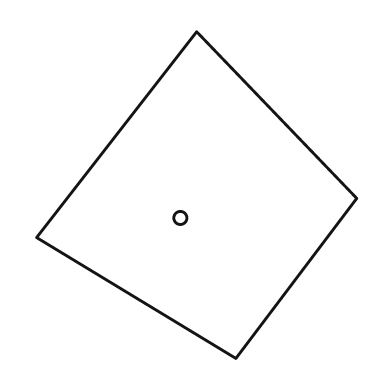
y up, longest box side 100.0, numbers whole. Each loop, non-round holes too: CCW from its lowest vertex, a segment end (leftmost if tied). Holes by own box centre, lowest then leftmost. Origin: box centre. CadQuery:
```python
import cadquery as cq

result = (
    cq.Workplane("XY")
    .moveTo(12.0, -50.0)
    .lineTo(49.0, -1.0)
    .lineTo(0.0, 50.0)
    .lineTo(-49.0, -13.0)
    .close()
    .moveTo(-5.0, -7.0)
    .circle(2.0)
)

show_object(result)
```